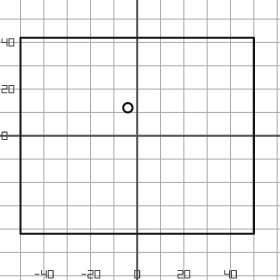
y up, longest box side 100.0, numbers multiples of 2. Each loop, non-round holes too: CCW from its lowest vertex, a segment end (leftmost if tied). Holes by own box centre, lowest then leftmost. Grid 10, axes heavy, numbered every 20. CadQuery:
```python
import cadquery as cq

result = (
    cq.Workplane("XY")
    .moveTo(-50.0, -42.0)
    .lineTo(50.0, -42.0)
    .lineTo(50.0, 42.0)
    .lineTo(-50.0, 42.0)
    .close()
    .moveTo(-4.0, 12.0)
    .circle(2.0)
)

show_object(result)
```